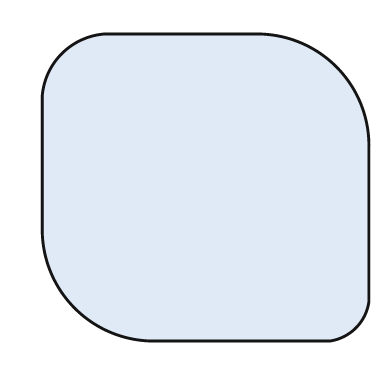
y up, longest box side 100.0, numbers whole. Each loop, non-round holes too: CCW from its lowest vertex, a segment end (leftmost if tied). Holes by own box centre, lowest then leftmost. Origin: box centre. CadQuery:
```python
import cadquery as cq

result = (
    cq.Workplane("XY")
    .moveTo(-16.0, -47.0)
    .lineTo(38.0, -47.0)
    .threePointArc((46.0, -43.0), (50.0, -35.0))
    .lineTo(50.0, 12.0)
    .threePointArc((40.0, 37.0), (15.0, 47.0))
    .lineTo(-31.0, 47.0)
    .threePointArc((-44.0, 41.0), (-50.0, 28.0))
    .lineTo(-50.0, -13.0)
    .threePointArc((-40.0, -37.0), (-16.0, -47.0))
    .close()
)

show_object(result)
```